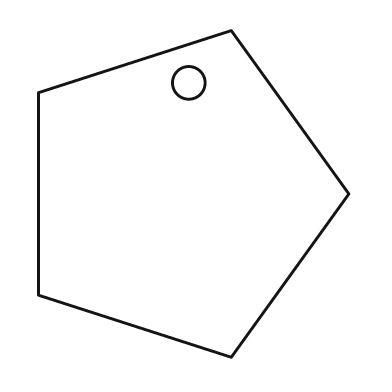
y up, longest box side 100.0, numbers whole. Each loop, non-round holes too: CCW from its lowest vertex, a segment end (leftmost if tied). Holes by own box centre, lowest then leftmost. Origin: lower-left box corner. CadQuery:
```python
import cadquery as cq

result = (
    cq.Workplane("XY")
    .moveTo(59.0, 0.0)
    .lineTo(95.0, 50.0)
    .lineTo(59.0, 100.0)
    .lineTo(0.0, 81.0)
    .lineTo(0.0, 19.0)
    .close()
    .moveTo(46.0, 84.0)
    .circle(5.0)
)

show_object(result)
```